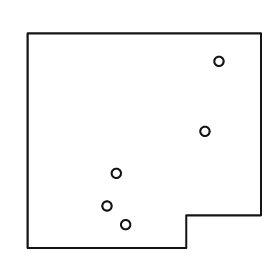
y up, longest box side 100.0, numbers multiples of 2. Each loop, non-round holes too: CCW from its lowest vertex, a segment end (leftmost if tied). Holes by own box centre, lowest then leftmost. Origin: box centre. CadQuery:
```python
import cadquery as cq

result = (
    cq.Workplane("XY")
    .moveTo(-50.0, -46.0)
    .lineTo(18.0, -46.0)
    .lineTo(18.0, -32.0)
    .lineTo(50.0, -32.0)
    .lineTo(50.0, 46.0)
    .lineTo(-50.0, 46.0)
    .close()
    .moveTo(-8.0, -36.0)
    .circle(2.0)
    .moveTo(-16.0, -28.0)
    .circle(2.0)
    .moveTo(-12.0, -14.0)
    .circle(2.0)
    .moveTo(26.0, 4.0)
    .circle(2.0)
    .moveTo(32.0, 34.0)
    .circle(2.0)
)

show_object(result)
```